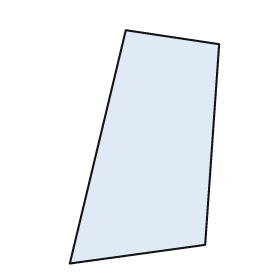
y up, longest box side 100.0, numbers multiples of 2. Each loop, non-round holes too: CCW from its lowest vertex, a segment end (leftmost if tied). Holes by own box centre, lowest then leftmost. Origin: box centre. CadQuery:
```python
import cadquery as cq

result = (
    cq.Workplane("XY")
    .moveTo(-32.0, -50.0)
    .lineTo(26.0, -42.0)
    .lineTo(32.0, 44.0)
    .lineTo(-8.0, 50.0)
    .close()
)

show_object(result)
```